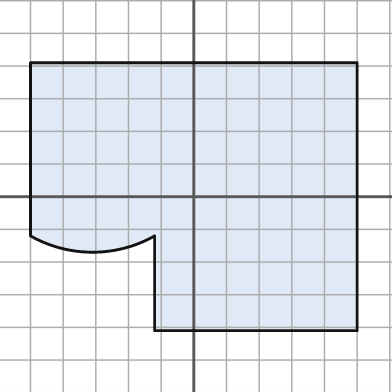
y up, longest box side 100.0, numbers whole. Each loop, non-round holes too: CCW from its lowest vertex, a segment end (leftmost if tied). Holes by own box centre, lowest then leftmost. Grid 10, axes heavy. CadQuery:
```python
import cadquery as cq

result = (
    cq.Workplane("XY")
    .moveTo(-12.0, -41.0)
    .lineTo(50.0, -41.0)
    .lineTo(50.0, 41.0)
    .lineTo(-50.0, 41.0)
    .lineTo(-50.0, -12.0)
    .threePointArc((-31.0, -17.0), (-12.0, -12.0))
    .close()
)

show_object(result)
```